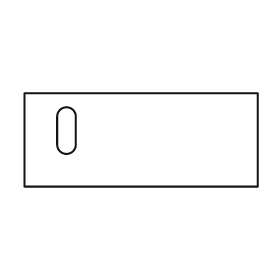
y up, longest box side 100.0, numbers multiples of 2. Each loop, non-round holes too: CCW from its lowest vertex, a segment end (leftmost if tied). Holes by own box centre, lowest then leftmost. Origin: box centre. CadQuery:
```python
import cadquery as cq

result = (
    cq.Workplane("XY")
    .moveTo(-50.0, -20.0)
    .lineTo(50.0, -20.0)
    .lineTo(50.0, 20.0)
    .lineTo(-50.0, 20.0)
    .close()
    .moveTo(-36.0, -2.0)
    .threePointArc((-32.0, -6.0), (-28.0, -2.0))
    .lineTo(-28.0, 10.0)
    .threePointArc((-32.0, 14.0), (-36.0, 10.0))
    .close()
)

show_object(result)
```